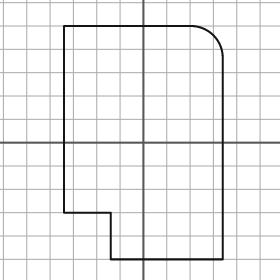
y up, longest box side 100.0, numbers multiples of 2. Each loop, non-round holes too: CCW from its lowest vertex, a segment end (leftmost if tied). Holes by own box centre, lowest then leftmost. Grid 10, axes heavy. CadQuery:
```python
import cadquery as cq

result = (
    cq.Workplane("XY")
    .moveTo(-14.0, -50.0)
    .lineTo(34.0, -50.0)
    .lineTo(34.0, 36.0)
    .threePointArc((30.0, 46.0), (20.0, 50.0))
    .lineTo(-34.0, 50.0)
    .lineTo(-34.0, -30.0)
    .lineTo(-14.0, -30.0)
    .close()
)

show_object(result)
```